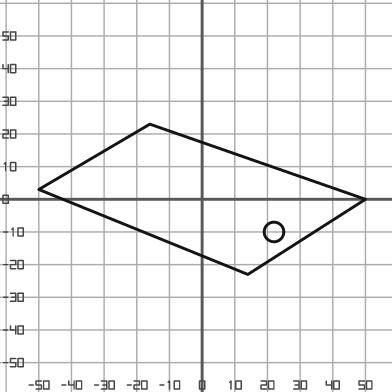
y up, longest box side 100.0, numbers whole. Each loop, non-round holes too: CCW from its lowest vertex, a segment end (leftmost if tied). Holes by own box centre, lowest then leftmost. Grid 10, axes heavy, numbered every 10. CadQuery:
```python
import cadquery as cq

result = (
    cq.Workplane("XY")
    .moveTo(14.0, -23.0)
    .lineTo(50.0, 0.0)
    .lineTo(-16.0, 23.0)
    .lineTo(-50.0, 3.0)
    .close()
    .moveTo(22.0, -10.0)
    .circle(3.0)
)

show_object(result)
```